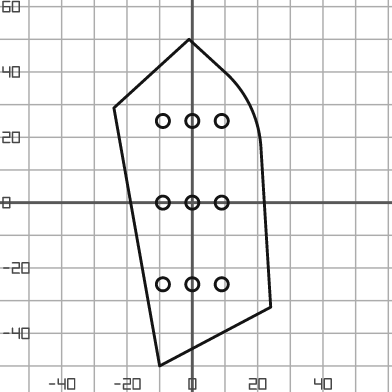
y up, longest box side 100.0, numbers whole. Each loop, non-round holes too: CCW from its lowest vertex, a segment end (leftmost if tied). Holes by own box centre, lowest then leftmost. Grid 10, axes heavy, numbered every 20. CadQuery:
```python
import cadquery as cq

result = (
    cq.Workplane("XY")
    .moveTo(-10.0, -50.0)
    .lineTo(24.0, -32.0)
    .lineTo(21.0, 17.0)
    .threePointArc((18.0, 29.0), (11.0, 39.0))
    .lineTo(-1.0, 50.0)
    .lineTo(-24.0, 29.0)
    .close()
    .moveTo(-9.0, -25.0)
    .circle(2.0)
    .moveTo(0.0, -25.0)
    .circle(2.0)
    .moveTo(9.0, -25.0)
    .circle(2.0)
    .moveTo(-9.0, 0.0)
    .circle(2.0)
    .moveTo(0.0, 0.0)
    .circle(2.0)
    .moveTo(9.0, 0.0)
    .circle(2.0)
    .moveTo(-9.0, 25.0)
    .circle(2.0)
    .moveTo(0.0, 25.0)
    .circle(2.0)
    .moveTo(9.0, 25.0)
    .circle(2.0)
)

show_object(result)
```